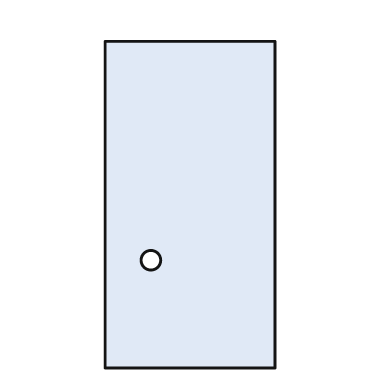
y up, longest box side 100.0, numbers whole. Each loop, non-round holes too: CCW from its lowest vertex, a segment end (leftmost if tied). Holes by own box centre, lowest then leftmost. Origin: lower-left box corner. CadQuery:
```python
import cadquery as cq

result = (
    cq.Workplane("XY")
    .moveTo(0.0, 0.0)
    .lineTo(52.0, 0.0)
    .lineTo(52.0, 100.0)
    .lineTo(0.0, 100.0)
    .close()
    .moveTo(14.0, 33.0)
    .circle(3.0)
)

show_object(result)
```